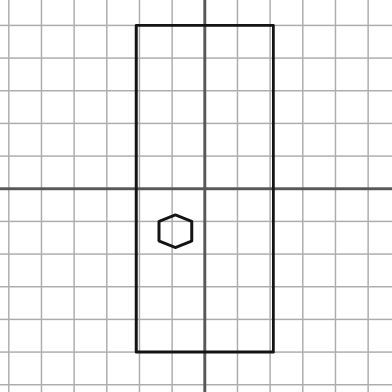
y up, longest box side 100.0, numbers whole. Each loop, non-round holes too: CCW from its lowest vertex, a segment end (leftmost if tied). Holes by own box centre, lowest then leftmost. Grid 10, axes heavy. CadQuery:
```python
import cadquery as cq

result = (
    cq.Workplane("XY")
    .moveTo(-21.0, -50.0)
    .lineTo(21.0, -50.0)
    .lineTo(21.0, 50.0)
    .lineTo(-21.0, 50.0)
    .close()
    .moveTo(-9.0, -18.0)
    .lineTo(-4.0, -16.0)
    .lineTo(-4.0, -10.0)
    .lineTo(-9.0, -8.0)
    .lineTo(-14.0, -10.0)
    .lineTo(-14.0, -16.0)
    .close()
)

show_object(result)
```